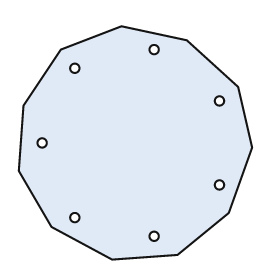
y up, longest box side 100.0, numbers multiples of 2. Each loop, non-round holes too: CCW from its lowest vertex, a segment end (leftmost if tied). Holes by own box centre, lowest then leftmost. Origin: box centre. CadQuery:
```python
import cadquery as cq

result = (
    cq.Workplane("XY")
    .moveTo(-10.0, -50.0)
    .lineTo(18.0, -48.0)
    .lineTo(40.0, -30.0)
    .lineTo(50.0, -2.0)
    .lineTo(44.0, 24.0)
    .lineTo(22.0, 44.0)
    .lineTo(-6.0, 50.0)
    .lineTo(-32.0, 40.0)
    .lineTo(-48.0, 16.0)
    .lineTo(-50.0, -12.0)
    .lineTo(-36.0, -36.0)
    .close()
    .moveTo(8.0, -40.0)
    .circle(2.0)
    .moveTo(-26.0, -32.0)
    .circle(2.0)
    .moveTo(36.0, -18.0)
    .circle(2.0)
    .moveTo(-40.0, 0.0)
    .circle(2.0)
    .moveTo(36.0, 18.0)
    .circle(2.0)
    .moveTo(-26.0, 32.0)
    .circle(2.0)
    .moveTo(8.0, 40.0)
    .circle(2.0)
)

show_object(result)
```